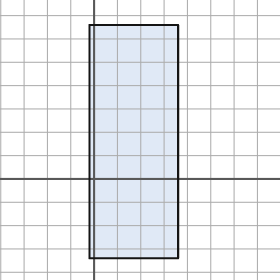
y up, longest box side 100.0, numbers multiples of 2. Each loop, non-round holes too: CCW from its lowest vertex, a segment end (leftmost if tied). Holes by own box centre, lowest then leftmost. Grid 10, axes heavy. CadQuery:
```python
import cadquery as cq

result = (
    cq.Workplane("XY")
    .moveTo(-2.0, -34.0)
    .lineTo(36.0, -34.0)
    .lineTo(36.0, 66.0)
    .lineTo(-2.0, 66.0)
    .close()
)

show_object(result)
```